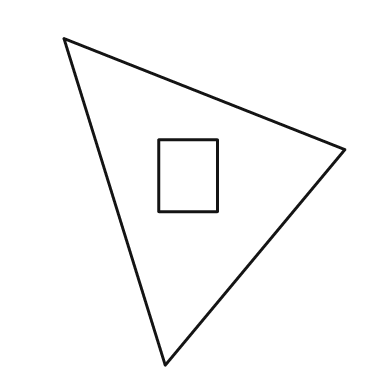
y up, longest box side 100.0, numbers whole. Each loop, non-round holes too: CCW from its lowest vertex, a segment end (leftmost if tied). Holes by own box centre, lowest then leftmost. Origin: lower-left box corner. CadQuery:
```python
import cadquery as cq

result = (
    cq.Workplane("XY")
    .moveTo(31.0, 0.0)
    .lineTo(86.0, 66.0)
    .lineTo(0.0, 100.0)
    .close()
    .moveTo(29.0, 47.0)
    .lineTo(47.0, 47.0)
    .lineTo(47.0, 69.0)
    .lineTo(29.0, 69.0)
    .close()
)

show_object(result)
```